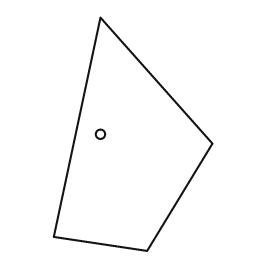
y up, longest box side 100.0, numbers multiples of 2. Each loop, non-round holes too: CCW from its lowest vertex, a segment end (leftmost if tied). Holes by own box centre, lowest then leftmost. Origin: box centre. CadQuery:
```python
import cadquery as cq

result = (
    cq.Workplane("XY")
    .moveTo(6.0, -50.0)
    .lineTo(34.0, -4.0)
    .lineTo(-14.0, 50.0)
    .lineTo(-34.0, -44.0)
    .close()
    .moveTo(-14.0, 0.0)
    .circle(2.0)
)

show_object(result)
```